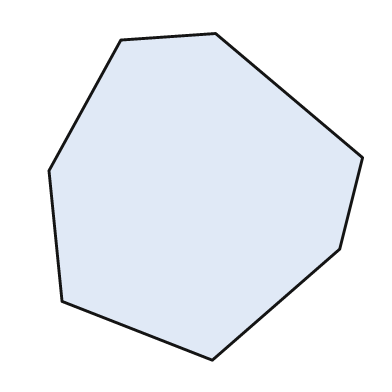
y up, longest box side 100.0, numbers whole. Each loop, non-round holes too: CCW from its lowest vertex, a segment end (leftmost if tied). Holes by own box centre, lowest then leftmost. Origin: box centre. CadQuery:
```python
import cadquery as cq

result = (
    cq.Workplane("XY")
    .moveTo(2.0, -50.0)
    .lineTo(41.0, -16.0)
    .lineTo(48.0, 12.0)
    .lineTo(3.0, 50.0)
    .lineTo(-26.0, 48.0)
    .lineTo(-48.0, 8.0)
    .lineTo(-44.0, -32.0)
    .close()
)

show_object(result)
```